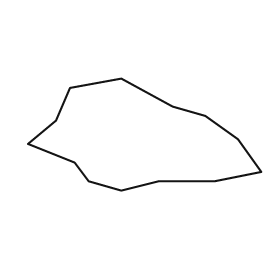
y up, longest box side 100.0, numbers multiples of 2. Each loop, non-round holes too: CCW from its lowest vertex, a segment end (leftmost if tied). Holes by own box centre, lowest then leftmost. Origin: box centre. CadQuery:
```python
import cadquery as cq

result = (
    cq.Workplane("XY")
    .moveTo(-10.0, -24.0)
    .lineTo(6.0, -20.0)
    .lineTo(30.0, -20.0)
    .lineTo(50.0, -16.0)
    .lineTo(40.0, -2.0)
    .lineTo(26.0, 8.0)
    .lineTo(12.0, 12.0)
    .lineTo(-10.0, 24.0)
    .lineTo(-32.0, 20.0)
    .lineTo(-38.0, 6.0)
    .lineTo(-50.0, -4.0)
    .lineTo(-30.0, -12.0)
    .lineTo(-24.0, -20.0)
    .close()
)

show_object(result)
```